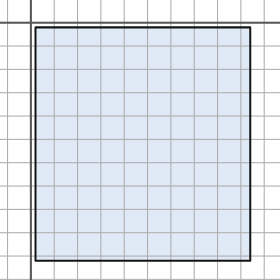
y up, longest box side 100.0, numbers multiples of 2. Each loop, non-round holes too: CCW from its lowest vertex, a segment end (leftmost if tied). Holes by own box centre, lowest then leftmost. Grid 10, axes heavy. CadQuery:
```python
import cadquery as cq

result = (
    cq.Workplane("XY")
    .moveTo(2.0, -102.0)
    .lineTo(94.0, -102.0)
    .lineTo(94.0, -2.0)
    .lineTo(2.0, -2.0)
    .close()
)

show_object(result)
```